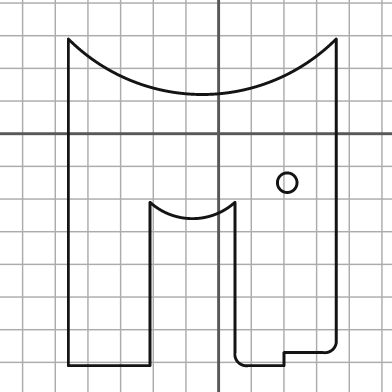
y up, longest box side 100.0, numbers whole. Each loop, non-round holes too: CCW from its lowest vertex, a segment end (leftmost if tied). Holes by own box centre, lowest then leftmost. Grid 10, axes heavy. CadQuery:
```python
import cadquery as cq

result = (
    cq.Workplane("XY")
    .moveTo(-46.0, -71.0)
    .lineTo(-21.0, -71.0)
    .lineTo(-21.0, -21.0)
    .threePointArc((-8.0, -26.0), (5.0, -21.0))
    .lineTo(5.0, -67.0)
    .threePointArc((6.0, -70.0), (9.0, -71.0))
    .lineTo(20.0, -71.0)
    .lineTo(20.0, -67.0)
    .lineTo(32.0, -67.0)
    .threePointArc((35.0, -66.0), (36.0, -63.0))
    .lineTo(36.0, 29.0)
    .threePointArc((-5.0, 12.0), (-46.0, 29.0))
    .close()
    .moveTo(21.0, -15.0)
    .circle(3.0)
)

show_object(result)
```